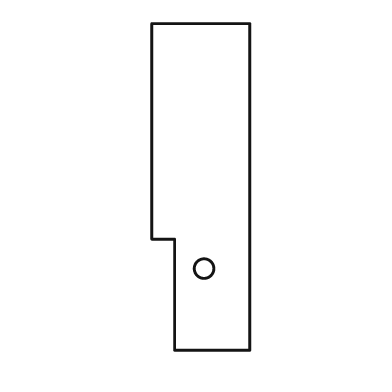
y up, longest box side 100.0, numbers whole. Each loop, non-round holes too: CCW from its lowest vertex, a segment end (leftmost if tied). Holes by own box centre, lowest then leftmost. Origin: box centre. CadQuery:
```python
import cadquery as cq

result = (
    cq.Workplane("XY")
    .moveTo(-8.0, -50.0)
    .lineTo(15.0, -50.0)
    .lineTo(15.0, 50.0)
    .lineTo(-15.0, 50.0)
    .lineTo(-15.0, -16.0)
    .lineTo(-8.0, -16.0)
    .close()
    .moveTo(1.0, -25.0)
    .circle(3.0)
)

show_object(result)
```